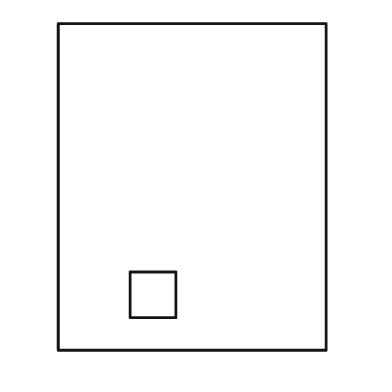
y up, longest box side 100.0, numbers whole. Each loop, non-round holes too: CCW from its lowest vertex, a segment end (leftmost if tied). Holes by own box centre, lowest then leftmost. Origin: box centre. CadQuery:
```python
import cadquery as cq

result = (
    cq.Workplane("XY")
    .moveTo(-41.0, -50.0)
    .lineTo(41.0, -50.0)
    .lineTo(41.0, 50.0)
    .lineTo(-41.0, 50.0)
    .close()
    .moveTo(-19.0, -40.0)
    .lineTo(-5.0, -40.0)
    .lineTo(-5.0, -26.0)
    .lineTo(-19.0, -26.0)
    .close()
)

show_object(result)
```